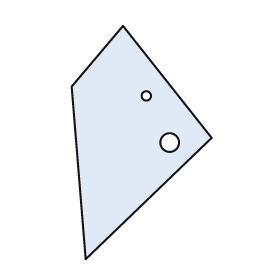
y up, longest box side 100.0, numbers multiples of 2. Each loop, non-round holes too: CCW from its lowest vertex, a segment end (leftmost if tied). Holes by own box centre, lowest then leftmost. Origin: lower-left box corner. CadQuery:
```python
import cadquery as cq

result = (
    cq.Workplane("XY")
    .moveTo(6.0, 0.0)
    .lineTo(60.0, 52.0)
    .lineTo(22.0, 100.0)
    .lineTo(0.0, 74.0)
    .close()
    .moveTo(42.0, 50.0)
    .circle(4.0)
    .moveTo(32.0, 70.0)
    .circle(2.0)
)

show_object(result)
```